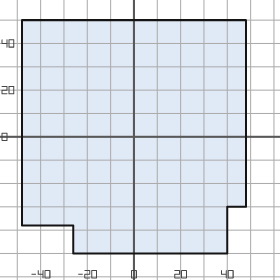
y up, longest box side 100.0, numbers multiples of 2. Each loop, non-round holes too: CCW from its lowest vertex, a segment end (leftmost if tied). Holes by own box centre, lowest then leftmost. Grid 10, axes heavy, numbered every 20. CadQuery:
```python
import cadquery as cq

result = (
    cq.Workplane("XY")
    .moveTo(-26.0, -50.0)
    .lineTo(40.0, -50.0)
    .lineTo(40.0, -30.0)
    .lineTo(48.0, -30.0)
    .lineTo(48.0, 50.0)
    .lineTo(-48.0, 50.0)
    .lineTo(-48.0, -38.0)
    .lineTo(-26.0, -38.0)
    .close()
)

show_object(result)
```